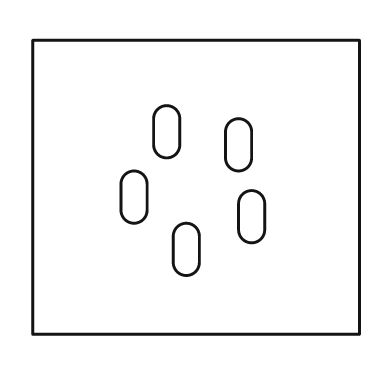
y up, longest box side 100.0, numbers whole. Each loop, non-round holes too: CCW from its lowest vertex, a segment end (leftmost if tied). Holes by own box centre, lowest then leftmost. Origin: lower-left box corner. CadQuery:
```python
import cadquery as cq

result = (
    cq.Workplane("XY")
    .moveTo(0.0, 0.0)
    .lineTo(100.0, 0.0)
    .lineTo(100.0, 90.0)
    .lineTo(0.0, 90.0)
    .close()
    .moveTo(43.0, 22.0)
    .threePointArc((47.0, 18.0), (51.0, 22.0))
    .lineTo(51.0, 30.0)
    .threePointArc((47.0, 34.0), (43.0, 30.0))
    .close()
    .moveTo(63.0, 32.0)
    .threePointArc((67.0, 28.0), (71.0, 32.0))
    .lineTo(71.0, 40.0)
    .threePointArc((67.0, 44.0), (63.0, 40.0))
    .close()
    .moveTo(27.0, 38.0)
    .threePointArc((31.0, 34.0), (35.0, 38.0))
    .lineTo(35.0, 46.0)
    .threePointArc((31.0, 50.0), (27.0, 46.0))
    .close()
    .moveTo(59.0, 54.0)
    .threePointArc((63.0, 50.0), (67.0, 54.0))
    .lineTo(67.0, 62.0)
    .threePointArc((63.0, 66.0), (59.0, 62.0))
    .close()
    .moveTo(37.0, 58.0)
    .threePointArc((41.0, 54.0), (45.0, 58.0))
    .lineTo(45.0, 66.0)
    .threePointArc((41.0, 70.0), (37.0, 66.0))
    .close()
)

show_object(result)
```